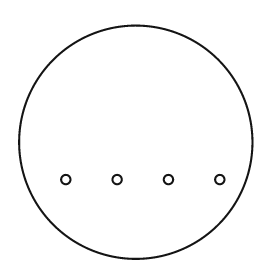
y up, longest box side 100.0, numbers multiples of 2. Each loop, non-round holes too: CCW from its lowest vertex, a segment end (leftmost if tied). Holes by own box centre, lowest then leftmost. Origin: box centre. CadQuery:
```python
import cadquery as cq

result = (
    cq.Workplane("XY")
    .moveTo(0.0, 0.0)
    .circle(50.0)
    .moveTo(-30.0, -16.0)
    .circle(2.0)
    .moveTo(-8.0, -16.0)
    .circle(2.0)
    .moveTo(14.0, -16.0)
    .circle(2.0)
    .moveTo(36.0, -16.0)
    .circle(2.0)
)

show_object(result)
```